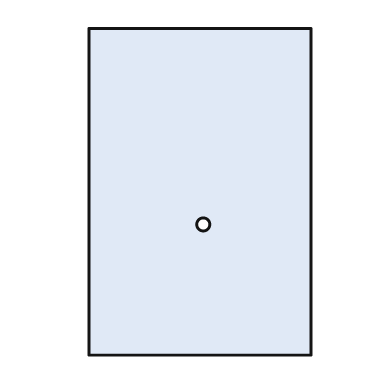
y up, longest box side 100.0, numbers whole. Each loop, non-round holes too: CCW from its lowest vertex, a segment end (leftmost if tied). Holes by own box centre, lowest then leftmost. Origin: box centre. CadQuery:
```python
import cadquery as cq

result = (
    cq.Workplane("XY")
    .moveTo(-34.0, -50.0)
    .lineTo(34.0, -50.0)
    .lineTo(34.0, 50.0)
    .lineTo(-34.0, 50.0)
    .close()
    .moveTo(1.0, -10.0)
    .circle(2.0)
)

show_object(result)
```